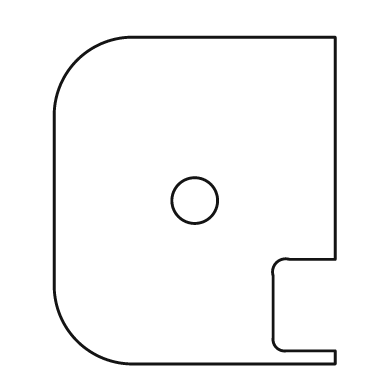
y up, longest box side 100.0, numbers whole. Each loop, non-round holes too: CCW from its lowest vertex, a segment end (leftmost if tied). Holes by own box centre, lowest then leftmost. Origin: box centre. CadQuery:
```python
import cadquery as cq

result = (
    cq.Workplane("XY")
    .moveTo(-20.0, -50.0)
    .lineTo(43.0, -50.0)
    .lineTo(43.0, -46.0)
    .lineTo(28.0, -46.0)
    .threePointArc((25.0, -45.0), (24.0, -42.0))
    .lineTo(24.0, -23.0)
    .threePointArc((25.0, -19.0), (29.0, -18.0))
    .lineTo(43.0, -18.0)
    .lineTo(43.0, 50.0)
    .lineTo(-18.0, 50.0)
    .threePointArc((-36.0, 43.0), (-43.0, 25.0))
    .lineTo(-43.0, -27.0)
    .threePointArc((-36.0, -43.0), (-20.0, -50.0))
    .close()
    .moveTo(0.0, 0.0)
    .circle(7.0)
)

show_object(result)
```